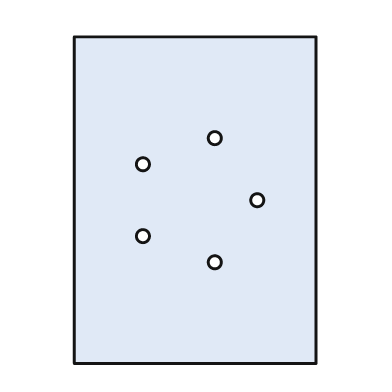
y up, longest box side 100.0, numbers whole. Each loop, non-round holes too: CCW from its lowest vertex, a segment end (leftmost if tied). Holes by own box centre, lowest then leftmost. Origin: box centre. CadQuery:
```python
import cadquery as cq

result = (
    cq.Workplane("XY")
    .moveTo(-37.0, -50.0)
    .lineTo(37.0, -50.0)
    .lineTo(37.0, 50.0)
    .lineTo(-37.0, 50.0)
    .close()
    .moveTo(6.0, -19.0)
    .circle(2.0)
    .moveTo(-16.0, -11.0)
    .circle(2.0)
    .moveTo(19.0, 0.0)
    .circle(2.0)
    .moveTo(-16.0, 11.0)
    .circle(2.0)
    .moveTo(6.0, 19.0)
    .circle(2.0)
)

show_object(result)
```